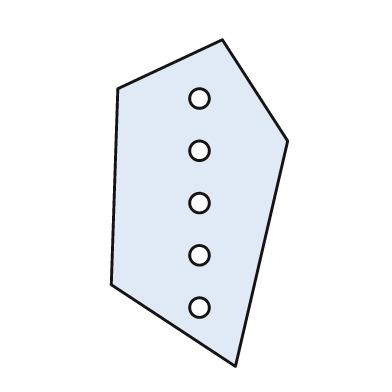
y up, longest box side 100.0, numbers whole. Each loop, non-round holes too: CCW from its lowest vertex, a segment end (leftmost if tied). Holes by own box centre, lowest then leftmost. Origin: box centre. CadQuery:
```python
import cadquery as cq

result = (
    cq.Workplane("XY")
    .moveTo(11.0, -50.0)
    .lineTo(27.0, 19.0)
    .lineTo(7.0, 50.0)
    .lineTo(-25.0, 35.0)
    .lineTo(-27.0, -25.0)
    .close()
    .moveTo(0.0, -32.0)
    .circle(3.0)
    .moveTo(0.0, -16.0)
    .circle(3.0)
    .moveTo(0.0, 0.0)
    .circle(3.0)
    .moveTo(0.0, 16.0)
    .circle(3.0)
    .moveTo(0.0, 32.0)
    .circle(3.0)
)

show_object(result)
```